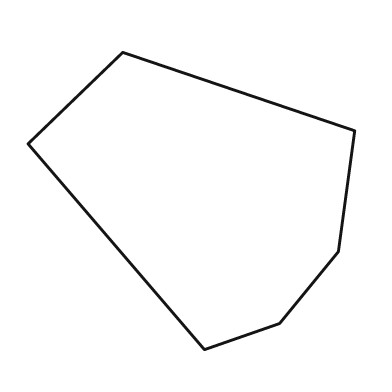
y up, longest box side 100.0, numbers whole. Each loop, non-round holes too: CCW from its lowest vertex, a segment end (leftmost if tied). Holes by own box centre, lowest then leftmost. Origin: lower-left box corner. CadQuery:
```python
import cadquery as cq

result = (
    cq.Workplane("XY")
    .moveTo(54.0, 0.0)
    .lineTo(77.0, 8.0)
    .lineTo(95.0, 30.0)
    .lineTo(100.0, 67.0)
    .lineTo(29.0, 91.0)
    .lineTo(0.0, 63.0)
    .close()
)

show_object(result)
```